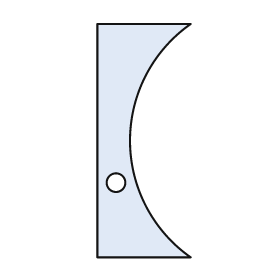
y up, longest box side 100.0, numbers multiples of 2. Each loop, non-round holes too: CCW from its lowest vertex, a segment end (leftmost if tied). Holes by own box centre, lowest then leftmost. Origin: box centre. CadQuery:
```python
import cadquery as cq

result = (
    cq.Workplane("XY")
    .moveTo(-20.0, -50.0)
    .lineTo(20.0, -50.0)
    .threePointArc((-6.0, 0.0), (20.0, 50.0))
    .lineTo(-20.0, 50.0)
    .close()
    .moveTo(-12.0, -18.0)
    .circle(4.0)
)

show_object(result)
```